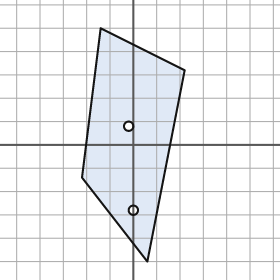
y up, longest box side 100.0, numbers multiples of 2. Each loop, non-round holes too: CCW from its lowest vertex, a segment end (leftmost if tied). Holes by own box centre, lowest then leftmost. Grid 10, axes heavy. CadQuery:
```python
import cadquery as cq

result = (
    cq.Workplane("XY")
    .moveTo(6.0, -50.0)
    .lineTo(22.0, 32.0)
    .lineTo(-14.0, 50.0)
    .lineTo(-22.0, -14.0)
    .close()
    .moveTo(0.0, -28.0)
    .circle(2.0)
    .moveTo(-2.0, 8.0)
    .circle(2.0)
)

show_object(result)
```